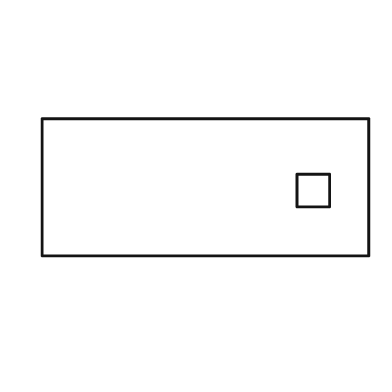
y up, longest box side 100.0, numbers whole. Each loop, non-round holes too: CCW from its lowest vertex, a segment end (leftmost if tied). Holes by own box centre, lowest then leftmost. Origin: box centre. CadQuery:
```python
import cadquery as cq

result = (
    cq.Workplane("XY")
    .moveTo(-50.0, -21.0)
    .lineTo(50.0, -21.0)
    .lineTo(50.0, 21.0)
    .lineTo(-50.0, 21.0)
    .close()
    .moveTo(28.0, -6.0)
    .lineTo(38.0, -6.0)
    .lineTo(38.0, 4.0)
    .lineTo(28.0, 4.0)
    .close()
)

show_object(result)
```